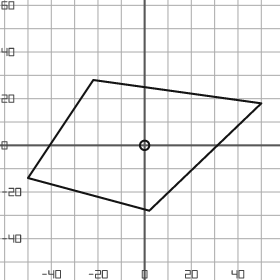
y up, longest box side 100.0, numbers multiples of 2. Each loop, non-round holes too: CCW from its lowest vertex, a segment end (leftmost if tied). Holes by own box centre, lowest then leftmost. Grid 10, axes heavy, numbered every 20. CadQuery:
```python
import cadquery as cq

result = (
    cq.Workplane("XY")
    .moveTo(2.0, -28.0)
    .lineTo(50.0, 18.0)
    .lineTo(-22.0, 28.0)
    .lineTo(-50.0, -14.0)
    .close()
    .moveTo(0.0, 0.0)
    .circle(2.0)
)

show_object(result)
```